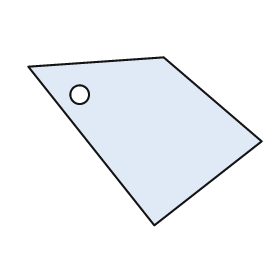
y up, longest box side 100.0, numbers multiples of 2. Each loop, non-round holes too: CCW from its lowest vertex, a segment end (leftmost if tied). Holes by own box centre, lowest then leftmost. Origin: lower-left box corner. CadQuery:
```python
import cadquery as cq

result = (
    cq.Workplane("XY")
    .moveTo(54.0, 0.0)
    .lineTo(100.0, 36.0)
    .lineTo(58.0, 72.0)
    .lineTo(0.0, 68.0)
    .close()
    .moveTo(22.0, 56.0)
    .circle(4.0)
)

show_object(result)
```